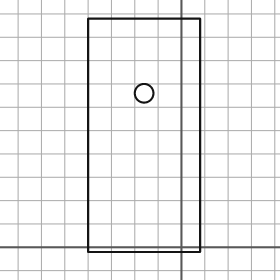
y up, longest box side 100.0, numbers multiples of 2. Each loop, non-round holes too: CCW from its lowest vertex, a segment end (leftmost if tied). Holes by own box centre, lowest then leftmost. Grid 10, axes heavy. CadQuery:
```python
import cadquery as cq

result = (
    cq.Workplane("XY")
    .moveTo(-40.0, -2.0)
    .lineTo(8.0, -2.0)
    .lineTo(8.0, 98.0)
    .lineTo(-40.0, 98.0)
    .close()
    .moveTo(-16.0, 66.0)
    .circle(4.0)
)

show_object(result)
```